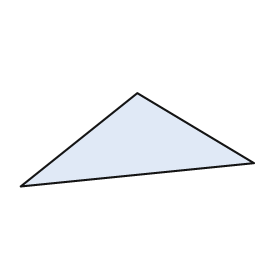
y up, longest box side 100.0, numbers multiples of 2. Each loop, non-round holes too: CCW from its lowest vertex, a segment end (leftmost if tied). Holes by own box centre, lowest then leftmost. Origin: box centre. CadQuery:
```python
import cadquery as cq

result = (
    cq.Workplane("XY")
    .moveTo(-50.0, -20.0)
    .lineTo(50.0, -10.0)
    .lineTo(0.0, 20.0)
    .close()
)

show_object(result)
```